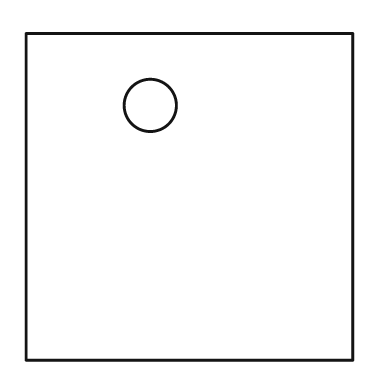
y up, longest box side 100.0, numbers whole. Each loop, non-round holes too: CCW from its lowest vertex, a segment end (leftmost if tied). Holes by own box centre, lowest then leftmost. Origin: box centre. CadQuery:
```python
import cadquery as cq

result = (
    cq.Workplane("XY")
    .moveTo(-50.0, -50.0)
    .lineTo(50.0, -50.0)
    .lineTo(50.0, 50.0)
    .lineTo(-50.0, 50.0)
    .close()
    .moveTo(-12.0, 28.0)
    .circle(8.0)
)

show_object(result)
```